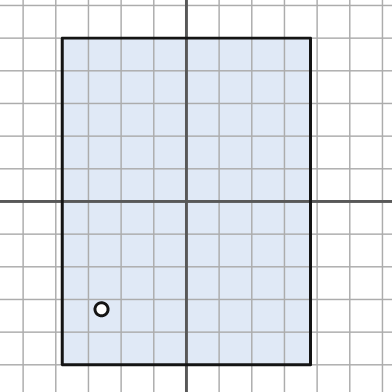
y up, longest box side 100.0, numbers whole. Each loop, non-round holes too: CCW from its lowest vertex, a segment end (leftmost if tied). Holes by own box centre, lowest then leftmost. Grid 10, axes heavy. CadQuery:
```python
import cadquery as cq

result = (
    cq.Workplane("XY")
    .moveTo(-38.0, -50.0)
    .lineTo(38.0, -50.0)
    .lineTo(38.0, 50.0)
    .lineTo(-38.0, 50.0)
    .close()
    .moveTo(-26.0, -33.0)
    .circle(2.0)
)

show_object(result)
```